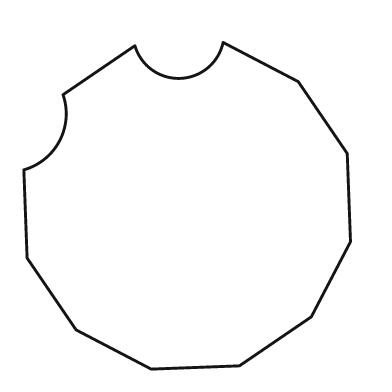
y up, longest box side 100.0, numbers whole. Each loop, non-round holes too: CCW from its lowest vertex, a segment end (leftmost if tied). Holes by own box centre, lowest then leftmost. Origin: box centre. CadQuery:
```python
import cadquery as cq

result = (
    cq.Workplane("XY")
    .moveTo(-11.0, -50.0)
    .lineTo(16.0, -49.0)
    .lineTo(38.0, -34.0)
    .lineTo(50.0, -11.0)
    .lineTo(49.0, 16.0)
    .lineTo(34.0, 38.0)
    .lineTo(11.0, 50.0)
    .threePointArc((-2.0, 39.0), (-16.0, 49.0))
    .lineTo(-38.0, 34.0)
    .threePointArc((-39.0, 20.0), (-50.0, 11.0))
    .lineTo(-49.0, -16.0)
    .lineTo(-34.0, -38.0)
    .close()
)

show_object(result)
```